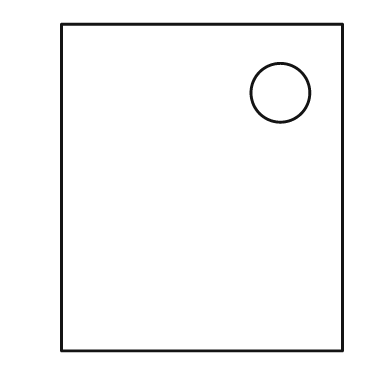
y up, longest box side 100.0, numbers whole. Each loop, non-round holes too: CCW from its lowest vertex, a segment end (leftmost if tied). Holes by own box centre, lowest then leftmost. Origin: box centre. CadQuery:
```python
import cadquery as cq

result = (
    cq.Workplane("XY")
    .moveTo(-43.0, -50.0)
    .lineTo(43.0, -50.0)
    .lineTo(43.0, 50.0)
    .lineTo(-43.0, 50.0)
    .close()
    .moveTo(24.0, 29.0)
    .circle(9.0)
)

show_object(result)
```